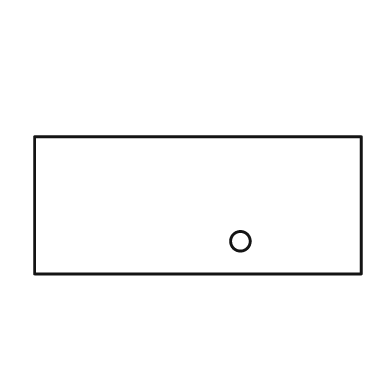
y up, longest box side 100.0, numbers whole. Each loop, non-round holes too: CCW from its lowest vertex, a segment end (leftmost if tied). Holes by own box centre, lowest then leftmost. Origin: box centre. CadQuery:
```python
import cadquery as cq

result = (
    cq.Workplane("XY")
    .moveTo(-50.0, -21.0)
    .lineTo(50.0, -21.0)
    .lineTo(50.0, 21.0)
    .lineTo(-50.0, 21.0)
    .close()
    .moveTo(13.0, -11.0)
    .circle(3.0)
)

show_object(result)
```